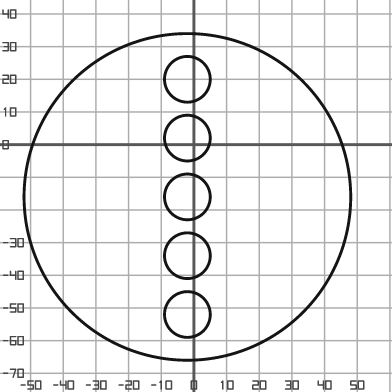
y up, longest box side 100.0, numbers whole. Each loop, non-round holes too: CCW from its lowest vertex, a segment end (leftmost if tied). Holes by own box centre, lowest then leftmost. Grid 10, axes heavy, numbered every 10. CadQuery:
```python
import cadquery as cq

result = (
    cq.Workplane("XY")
    .moveTo(-2.0, -16.0)
    .circle(50.0)
    .moveTo(-2.0, -52.0)
    .circle(7.0)
    .moveTo(-2.0, -34.0)
    .circle(7.0)
    .moveTo(-2.0, -16.0)
    .circle(7.0)
    .moveTo(-2.0, 2.0)
    .circle(7.0)
    .moveTo(-2.0, 20.0)
    .circle(7.0)
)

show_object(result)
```